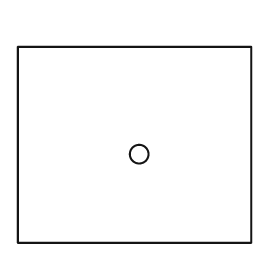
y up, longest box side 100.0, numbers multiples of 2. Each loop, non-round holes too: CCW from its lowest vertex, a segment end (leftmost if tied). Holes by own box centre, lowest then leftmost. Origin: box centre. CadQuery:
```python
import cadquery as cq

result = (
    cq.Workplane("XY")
    .moveTo(-50.0, -42.0)
    .lineTo(50.0, -42.0)
    .lineTo(50.0, 42.0)
    .lineTo(-50.0, 42.0)
    .close()
    .moveTo(2.0, -4.0)
    .circle(4.0)
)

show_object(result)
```